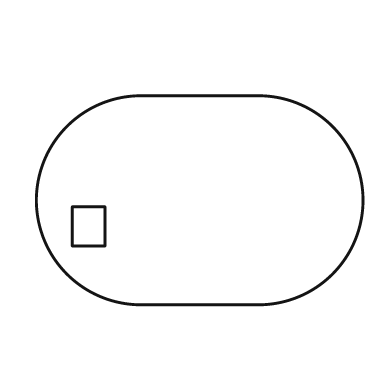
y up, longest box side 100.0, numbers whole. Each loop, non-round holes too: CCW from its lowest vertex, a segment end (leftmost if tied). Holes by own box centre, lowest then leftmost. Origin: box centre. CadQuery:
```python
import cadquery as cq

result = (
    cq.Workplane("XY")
    .moveTo(-18.0, -32.0)
    .lineTo(18.0, -32.0)
    .threePointArc((50.0, 0.0), (18.0, 32.0))
    .lineTo(-18.0, 32.0)
    .threePointArc((-50.0, 0.0), (-18.0, -32.0))
    .close()
    .moveTo(-39.0, -14.0)
    .lineTo(-29.0, -14.0)
    .lineTo(-29.0, -2.0)
    .lineTo(-39.0, -2.0)
    .close()
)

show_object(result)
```